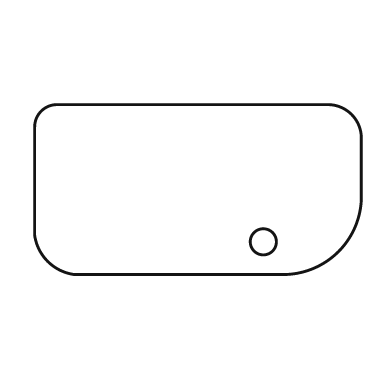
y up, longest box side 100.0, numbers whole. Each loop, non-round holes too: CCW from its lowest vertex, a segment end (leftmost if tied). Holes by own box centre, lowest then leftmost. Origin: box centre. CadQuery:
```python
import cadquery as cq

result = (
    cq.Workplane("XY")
    .moveTo(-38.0, -26.0)
    .lineTo(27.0, -26.0)
    .threePointArc((43.0, -19.0), (50.0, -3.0))
    .lineTo(50.0, 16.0)
    .threePointArc((47.0, 23.0), (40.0, 26.0))
    .lineTo(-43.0, 26.0)
    .threePointArc((-48.0, 24.0), (-50.0, 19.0))
    .lineTo(-50.0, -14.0)
    .threePointArc((-46.0, -22.0), (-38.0, -26.0))
    .close()
    .moveTo(20.0, -16.0)
    .circle(4.0)
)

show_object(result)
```